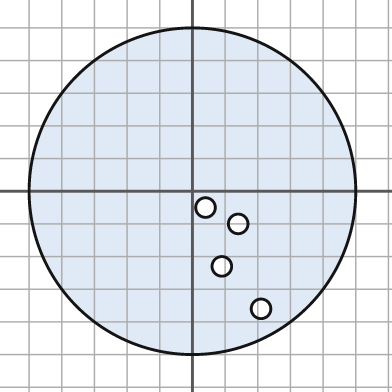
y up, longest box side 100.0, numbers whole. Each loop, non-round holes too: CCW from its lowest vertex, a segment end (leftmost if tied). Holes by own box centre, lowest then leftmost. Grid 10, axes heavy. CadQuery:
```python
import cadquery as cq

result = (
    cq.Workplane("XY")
    .moveTo(0.0, 0.0)
    .circle(50.0)
    .moveTo(21.0, -36.0)
    .circle(3.0)
    .moveTo(9.0, -23.0)
    .circle(3.0)
    .moveTo(14.0, -10.0)
    .circle(3.0)
    .moveTo(4.0, -5.0)
    .circle(3.0)
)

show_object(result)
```